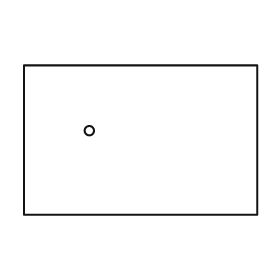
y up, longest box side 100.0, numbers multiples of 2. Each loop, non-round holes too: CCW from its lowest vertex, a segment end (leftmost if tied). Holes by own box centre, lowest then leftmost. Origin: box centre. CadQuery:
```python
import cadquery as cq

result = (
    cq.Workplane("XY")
    .moveTo(-50.0, -32.0)
    .lineTo(50.0, -32.0)
    .lineTo(50.0, 32.0)
    .lineTo(-50.0, 32.0)
    .close()
    .moveTo(-22.0, 4.0)
    .circle(2.0)
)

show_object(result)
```